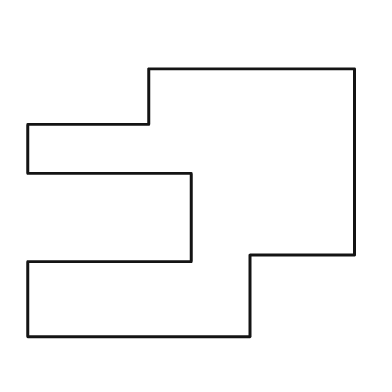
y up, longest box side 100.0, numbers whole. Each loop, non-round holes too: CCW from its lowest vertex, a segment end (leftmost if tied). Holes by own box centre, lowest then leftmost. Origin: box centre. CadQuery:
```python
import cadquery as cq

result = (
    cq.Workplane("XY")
    .moveTo(-50.0, -41.0)
    .lineTo(18.0, -41.0)
    .lineTo(18.0, -16.0)
    .lineTo(50.0, -16.0)
    .lineTo(50.0, 41.0)
    .lineTo(-13.0, 41.0)
    .lineTo(-13.0, 24.0)
    .lineTo(-50.0, 24.0)
    .lineTo(-50.0, 9.0)
    .lineTo(0.0, 9.0)
    .lineTo(0.0, -18.0)
    .lineTo(-50.0, -18.0)
    .close()
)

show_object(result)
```